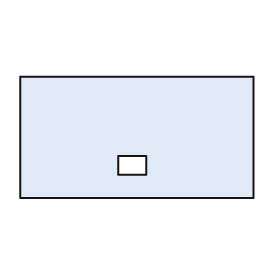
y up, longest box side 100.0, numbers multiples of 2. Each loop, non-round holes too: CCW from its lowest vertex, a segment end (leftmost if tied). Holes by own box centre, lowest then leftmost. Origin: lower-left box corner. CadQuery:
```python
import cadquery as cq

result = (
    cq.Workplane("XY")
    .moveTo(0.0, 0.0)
    .lineTo(100.0, 0.0)
    .lineTo(100.0, 52.0)
    .lineTo(0.0, 52.0)
    .close()
    .moveTo(42.0, 10.0)
    .lineTo(54.0, 10.0)
    .lineTo(54.0, 18.0)
    .lineTo(42.0, 18.0)
    .close()
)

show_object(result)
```